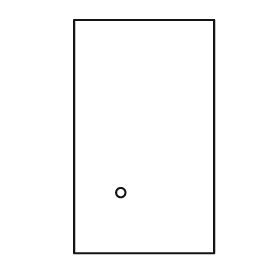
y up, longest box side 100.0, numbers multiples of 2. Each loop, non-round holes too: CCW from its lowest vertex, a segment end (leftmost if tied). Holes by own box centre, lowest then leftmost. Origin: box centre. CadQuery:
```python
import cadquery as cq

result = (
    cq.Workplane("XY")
    .moveTo(-30.0, -50.0)
    .lineTo(30.0, -50.0)
    .lineTo(30.0, 50.0)
    .lineTo(-30.0, 50.0)
    .close()
    .moveTo(-10.0, -24.0)
    .circle(2.0)
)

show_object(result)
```